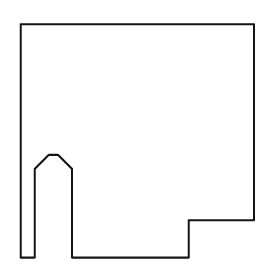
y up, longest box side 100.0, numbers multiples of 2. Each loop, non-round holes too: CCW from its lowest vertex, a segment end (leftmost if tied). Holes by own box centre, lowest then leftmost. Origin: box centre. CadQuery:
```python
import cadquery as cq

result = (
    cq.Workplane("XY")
    .moveTo(-50.0, -50.0)
    .lineTo(-44.0, -50.0)
    .lineTo(-44.0, -12.0)
    .lineTo(-38.0, -6.0)
    .lineTo(-34.0, -6.0)
    .lineTo(-28.0, -12.0)
    .lineTo(-28.0, -50.0)
    .lineTo(22.0, -50.0)
    .lineTo(22.0, -34.0)
    .lineTo(50.0, -34.0)
    .lineTo(50.0, 50.0)
    .lineTo(-50.0, 50.0)
    .close()
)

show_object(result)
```